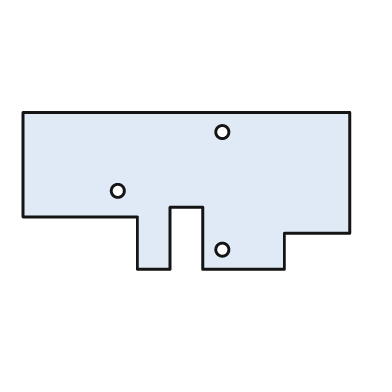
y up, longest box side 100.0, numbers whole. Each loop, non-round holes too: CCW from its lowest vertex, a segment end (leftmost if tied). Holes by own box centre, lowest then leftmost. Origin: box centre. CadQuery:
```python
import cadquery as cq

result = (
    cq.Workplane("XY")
    .moveTo(-15.0, -24.0)
    .lineTo(-5.0, -24.0)
    .lineTo(-5.0, -5.0)
    .lineTo(5.0, -5.0)
    .lineTo(5.0, -24.0)
    .lineTo(30.0, -24.0)
    .lineTo(30.0, -13.0)
    .lineTo(50.0, -13.0)
    .lineTo(50.0, 24.0)
    .lineTo(-50.0, 24.0)
    .lineTo(-50.0, -8.0)
    .lineTo(-15.0, -8.0)
    .close()
    .moveTo(11.0, -18.0)
    .circle(2.0)
    .moveTo(-21.0, 0.0)
    .circle(2.0)
    .moveTo(11.0, 18.0)
    .circle(2.0)
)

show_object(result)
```